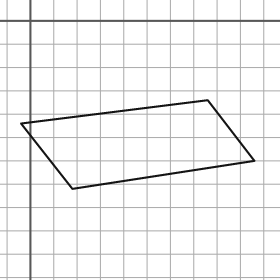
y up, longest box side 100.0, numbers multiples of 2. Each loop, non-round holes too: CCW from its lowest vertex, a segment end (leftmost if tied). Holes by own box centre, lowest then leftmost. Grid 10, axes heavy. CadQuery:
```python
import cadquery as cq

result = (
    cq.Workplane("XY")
    .moveTo(18.0, -72.0)
    .lineTo(96.0, -60.0)
    .lineTo(76.0, -34.0)
    .lineTo(-4.0, -44.0)
    .close()
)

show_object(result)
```